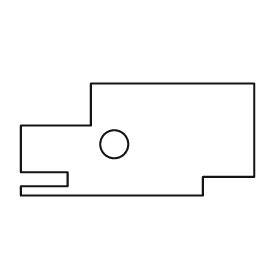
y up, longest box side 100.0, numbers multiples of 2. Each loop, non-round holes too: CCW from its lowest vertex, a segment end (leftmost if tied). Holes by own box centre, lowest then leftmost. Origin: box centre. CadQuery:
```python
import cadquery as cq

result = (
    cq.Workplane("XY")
    .moveTo(-50.0, -24.0)
    .lineTo(28.0, -24.0)
    .lineTo(28.0, -16.0)
    .lineTo(50.0, -16.0)
    .lineTo(50.0, 24.0)
    .lineTo(-20.0, 24.0)
    .lineTo(-20.0, 6.0)
    .lineTo(-50.0, 6.0)
    .lineTo(-50.0, -14.0)
    .lineTo(-30.0, -14.0)
    .lineTo(-30.0, -20.0)
    .lineTo(-50.0, -20.0)
    .close()
    .moveTo(-10.0, -2.0)
    .circle(6.0)
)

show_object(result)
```